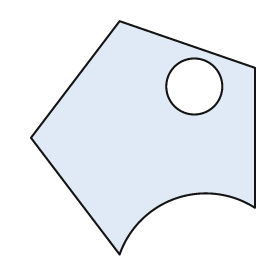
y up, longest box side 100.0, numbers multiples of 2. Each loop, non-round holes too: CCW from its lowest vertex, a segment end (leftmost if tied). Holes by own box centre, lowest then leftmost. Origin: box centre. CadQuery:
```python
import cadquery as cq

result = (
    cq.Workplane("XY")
    .moveTo(-10.0, -50.0)
    .threePointArc((14.0, -26.0), (48.0, -30.0))
    .lineTo(48.0, 30.0)
    .lineTo(-10.0, 50.0)
    .lineTo(-48.0, 0.0)
    .close()
    .moveTo(22.0, 22.0)
    .circle(12.0)
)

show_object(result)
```